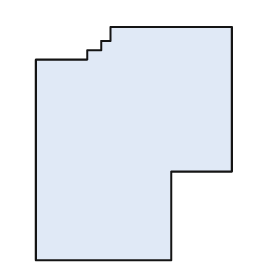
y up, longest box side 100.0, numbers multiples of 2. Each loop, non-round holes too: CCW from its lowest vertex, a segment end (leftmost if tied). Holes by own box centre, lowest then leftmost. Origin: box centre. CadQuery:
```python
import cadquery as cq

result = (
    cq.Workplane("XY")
    .moveTo(-42.0, -50.0)
    .lineTo(16.0, -50.0)
    .lineTo(16.0, -12.0)
    .lineTo(42.0, -12.0)
    .lineTo(42.0, 50.0)
    .lineTo(-10.0, 50.0)
    .lineTo(-10.0, 44.0)
    .lineTo(-14.0, 44.0)
    .lineTo(-14.0, 40.0)
    .lineTo(-20.0, 40.0)
    .lineTo(-20.0, 36.0)
    .lineTo(-42.0, 36.0)
    .close()
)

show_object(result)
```